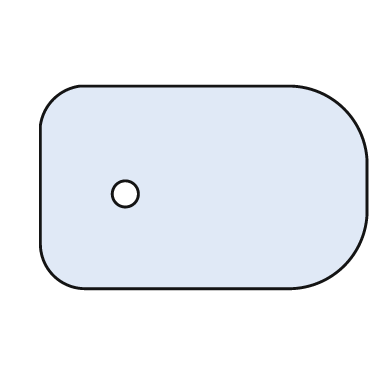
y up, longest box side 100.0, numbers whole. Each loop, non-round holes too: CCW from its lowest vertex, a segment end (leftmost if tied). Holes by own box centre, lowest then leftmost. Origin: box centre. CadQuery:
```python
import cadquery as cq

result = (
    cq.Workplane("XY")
    .moveTo(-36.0, -31.0)
    .lineTo(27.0, -31.0)
    .threePointArc((43.0, -24.0), (50.0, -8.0))
    .lineTo(50.0, 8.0)
    .threePointArc((43.0, 24.0), (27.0, 31.0))
    .lineTo(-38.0, 31.0)
    .threePointArc((-46.0, 27.0), (-50.0, 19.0))
    .lineTo(-50.0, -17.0)
    .threePointArc((-46.0, -27.0), (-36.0, -31.0))
    .close()
    .moveTo(-24.0, -2.0)
    .circle(4.0)
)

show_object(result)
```